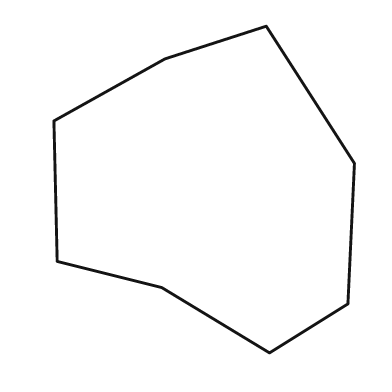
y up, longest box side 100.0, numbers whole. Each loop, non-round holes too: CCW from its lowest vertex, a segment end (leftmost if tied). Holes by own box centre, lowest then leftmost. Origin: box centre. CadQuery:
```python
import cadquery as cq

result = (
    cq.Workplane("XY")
    .moveTo(20.0, -50.0)
    .lineTo(44.0, -35.0)
    .lineTo(46.0, 8.0)
    .lineTo(19.0, 50.0)
    .lineTo(-12.0, 40.0)
    .lineTo(-46.0, 21.0)
    .lineTo(-45.0, -22.0)
    .lineTo(-13.0, -30.0)
    .close()
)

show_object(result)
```